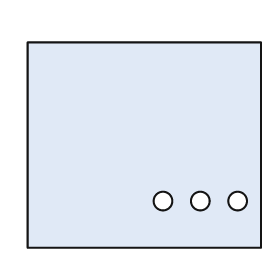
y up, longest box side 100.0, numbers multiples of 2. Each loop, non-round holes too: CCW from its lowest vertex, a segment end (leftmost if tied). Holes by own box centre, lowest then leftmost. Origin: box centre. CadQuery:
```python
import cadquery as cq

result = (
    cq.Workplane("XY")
    .moveTo(-50.0, -44.0)
    .lineTo(50.0, -44.0)
    .lineTo(50.0, 44.0)
    .lineTo(-50.0, 44.0)
    .close()
    .moveTo(8.0, -24.0)
    .circle(4.0)
    .moveTo(24.0, -24.0)
    .circle(4.0)
    .moveTo(40.0, -24.0)
    .circle(4.0)
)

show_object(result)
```